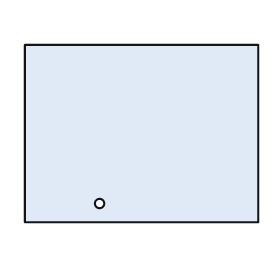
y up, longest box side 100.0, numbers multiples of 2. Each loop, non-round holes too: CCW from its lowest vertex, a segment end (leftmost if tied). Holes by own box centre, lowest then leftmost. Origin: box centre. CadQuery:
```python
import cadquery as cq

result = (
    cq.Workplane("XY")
    .moveTo(-50.0, -38.0)
    .lineTo(50.0, -38.0)
    .lineTo(50.0, 38.0)
    .lineTo(-50.0, 38.0)
    .close()
    .moveTo(-18.0, -30.0)
    .circle(2.0)
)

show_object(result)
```